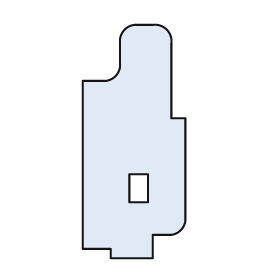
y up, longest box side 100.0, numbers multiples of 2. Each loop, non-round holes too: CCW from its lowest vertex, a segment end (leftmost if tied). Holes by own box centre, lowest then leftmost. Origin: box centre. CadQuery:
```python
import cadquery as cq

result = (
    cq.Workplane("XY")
    .moveTo(-10.0, -50.0)
    .lineTo(8.0, -50.0)
    .lineTo(8.0, -40.0)
    .lineTo(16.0, -40.0)
    .threePointArc((20.0, -38.0), (22.0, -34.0))
    .lineTo(22.0, 10.0)
    .lineTo(16.0, 10.0)
    .lineTo(16.0, 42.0)
    .threePointArc((14.0, 48.0), (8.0, 50.0))
    .lineTo(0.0, 50.0)
    .threePointArc((-4.0, 48.0), (-6.0, 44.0))
    .lineTo(-6.0, 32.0)
    .threePointArc((-8.0, 28.0), (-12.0, 26.0))
    .lineTo(-22.0, 26.0)
    .lineTo(-22.0, -46.0)
    .lineTo(-10.0, -46.0)
    .close()
    .moveTo(-2.0, -26.0)
    .lineTo(6.0, -26.0)
    .lineTo(6.0, -14.0)
    .lineTo(-2.0, -14.0)
    .close()
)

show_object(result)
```